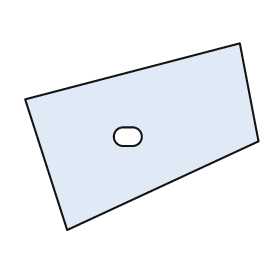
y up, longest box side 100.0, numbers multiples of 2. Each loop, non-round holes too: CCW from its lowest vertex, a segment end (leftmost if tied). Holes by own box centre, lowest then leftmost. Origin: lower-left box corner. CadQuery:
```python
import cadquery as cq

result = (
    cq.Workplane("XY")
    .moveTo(18.0, 0.0)
    .lineTo(100.0, 38.0)
    .lineTo(92.0, 80.0)
    .lineTo(0.0, 56.0)
    .close()
    .moveTo(42.0, 36.0)
    .lineTo(46.0, 36.0)
    .threePointArc((50.0, 40.0), (46.0, 44.0))
    .lineTo(42.0, 44.0)
    .threePointArc((38.0, 40.0), (42.0, 36.0))
    .close()
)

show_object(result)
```